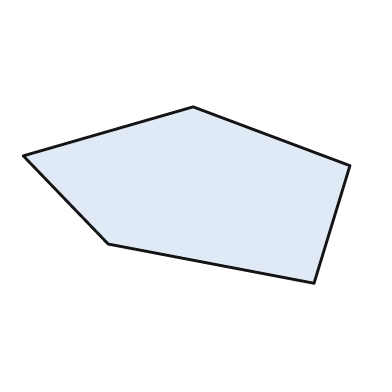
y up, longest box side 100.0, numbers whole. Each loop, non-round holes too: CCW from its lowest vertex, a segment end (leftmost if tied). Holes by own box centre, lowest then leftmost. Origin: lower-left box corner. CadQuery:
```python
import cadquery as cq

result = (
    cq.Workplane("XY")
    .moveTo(89.0, 0.0)
    .lineTo(100.0, 36.0)
    .lineTo(52.0, 54.0)
    .lineTo(0.0, 39.0)
    .lineTo(26.0, 12.0)
    .close()
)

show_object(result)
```